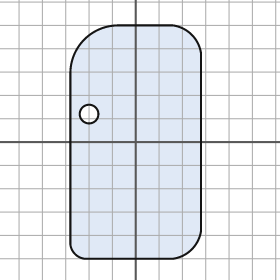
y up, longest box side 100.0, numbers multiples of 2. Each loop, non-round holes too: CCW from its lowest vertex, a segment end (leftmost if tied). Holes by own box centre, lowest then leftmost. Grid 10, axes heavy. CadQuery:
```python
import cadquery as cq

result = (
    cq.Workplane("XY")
    .moveTo(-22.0, -50.0)
    .lineTo(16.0, -50.0)
    .threePointArc((24.0, -46.0), (28.0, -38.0))
    .lineTo(28.0, 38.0)
    .threePointArc((24.0, 46.0), (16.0, 50.0))
    .lineTo(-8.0, 50.0)
    .threePointArc((-22.0, 44.0), (-28.0, 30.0))
    .lineTo(-28.0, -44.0)
    .threePointArc((-26.0, -48.0), (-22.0, -50.0))
    .close()
    .moveTo(-20.0, 12.0)
    .circle(4.0)
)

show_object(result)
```